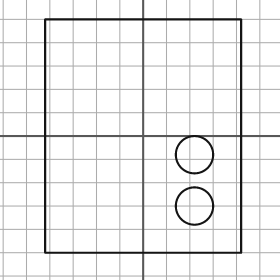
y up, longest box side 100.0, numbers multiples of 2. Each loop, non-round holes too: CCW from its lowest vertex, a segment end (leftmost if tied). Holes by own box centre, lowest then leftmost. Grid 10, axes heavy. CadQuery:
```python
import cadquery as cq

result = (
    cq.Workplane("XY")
    .moveTo(-42.0, -50.0)
    .lineTo(42.0, -50.0)
    .lineTo(42.0, 50.0)
    .lineTo(-42.0, 50.0)
    .close()
    .moveTo(22.0, -30.0)
    .circle(8.0)
    .moveTo(22.0, -8.0)
    .circle(8.0)
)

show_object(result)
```